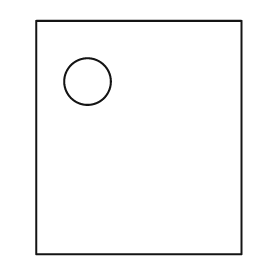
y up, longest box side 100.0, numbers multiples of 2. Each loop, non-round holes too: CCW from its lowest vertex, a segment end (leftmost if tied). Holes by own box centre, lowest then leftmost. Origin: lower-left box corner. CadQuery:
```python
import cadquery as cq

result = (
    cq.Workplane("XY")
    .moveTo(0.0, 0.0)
    .lineTo(88.0, 0.0)
    .lineTo(88.0, 100.0)
    .lineTo(0.0, 100.0)
    .close()
    .moveTo(22.0, 74.0)
    .circle(10.0)
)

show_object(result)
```